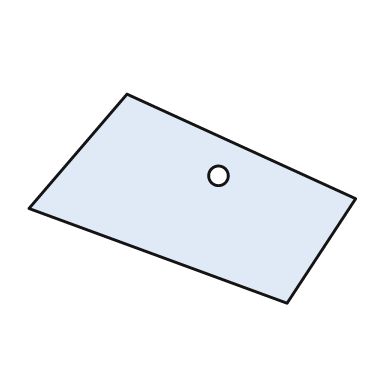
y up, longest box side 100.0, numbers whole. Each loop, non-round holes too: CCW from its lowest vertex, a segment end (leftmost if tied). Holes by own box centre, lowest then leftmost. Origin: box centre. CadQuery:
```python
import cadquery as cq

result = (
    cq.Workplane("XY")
    .moveTo(29.0, -32.0)
    .lineTo(50.0, 0.0)
    .lineTo(-20.0, 32.0)
    .lineTo(-50.0, -3.0)
    .close()
    .moveTo(8.0, 7.0)
    .circle(3.0)
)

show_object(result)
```